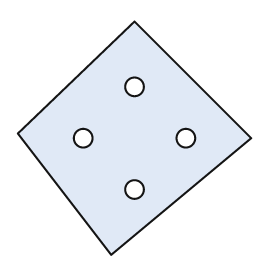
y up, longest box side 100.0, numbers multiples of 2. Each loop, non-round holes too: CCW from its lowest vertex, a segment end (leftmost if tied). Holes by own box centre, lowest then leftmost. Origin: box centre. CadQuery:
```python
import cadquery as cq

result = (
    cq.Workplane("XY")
    .moveTo(-10.0, -50.0)
    .lineTo(50.0, 0.0)
    .lineTo(0.0, 50.0)
    .lineTo(-50.0, 2.0)
    .close()
    .moveTo(0.0, -22.0)
    .circle(4.0)
    .moveTo(-22.0, 0.0)
    .circle(4.0)
    .moveTo(22.0, 0.0)
    .circle(4.0)
    .moveTo(0.0, 22.0)
    .circle(4.0)
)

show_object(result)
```